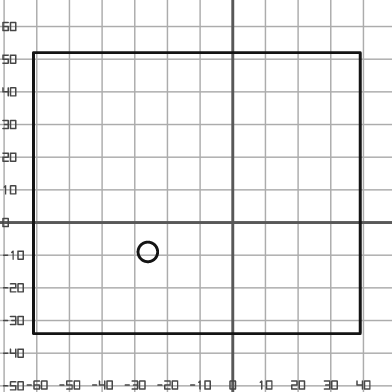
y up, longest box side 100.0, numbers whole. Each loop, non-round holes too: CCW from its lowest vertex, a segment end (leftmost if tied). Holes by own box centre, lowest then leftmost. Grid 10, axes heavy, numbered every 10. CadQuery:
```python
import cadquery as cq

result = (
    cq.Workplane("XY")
    .moveTo(-61.0, -34.0)
    .lineTo(39.0, -34.0)
    .lineTo(39.0, 52.0)
    .lineTo(-61.0, 52.0)
    .close()
    .moveTo(-26.0, -9.0)
    .circle(3.0)
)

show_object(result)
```